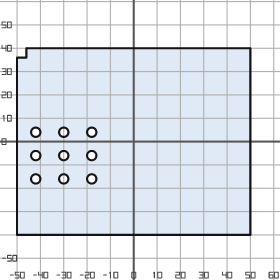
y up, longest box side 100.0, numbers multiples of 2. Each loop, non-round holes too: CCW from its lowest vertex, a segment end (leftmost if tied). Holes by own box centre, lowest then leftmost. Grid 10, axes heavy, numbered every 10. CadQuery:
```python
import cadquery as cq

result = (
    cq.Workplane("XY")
    .moveTo(-50.0, -40.0)
    .lineTo(50.0, -40.0)
    .lineTo(50.0, 40.0)
    .lineTo(-46.0, 40.0)
    .lineTo(-46.0, 36.0)
    .lineTo(-50.0, 36.0)
    .close()
    .moveTo(-42.0, -16.0)
    .circle(2.0)
    .moveTo(-30.0, -16.0)
    .circle(2.0)
    .moveTo(-18.0, -16.0)
    .circle(2.0)
    .moveTo(-42.0, -6.0)
    .circle(2.0)
    .moveTo(-30.0, -6.0)
    .circle(2.0)
    .moveTo(-18.0, -6.0)
    .circle(2.0)
    .moveTo(-42.0, 4.0)
    .circle(2.0)
    .moveTo(-30.0, 4.0)
    .circle(2.0)
    .moveTo(-18.0, 4.0)
    .circle(2.0)
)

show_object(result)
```